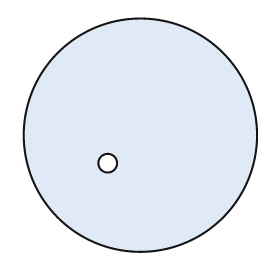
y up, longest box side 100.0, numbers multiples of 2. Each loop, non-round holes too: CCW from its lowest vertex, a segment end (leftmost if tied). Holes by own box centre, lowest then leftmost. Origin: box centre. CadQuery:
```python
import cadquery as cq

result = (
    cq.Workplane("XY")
    .moveTo(0.0, 0.0)
    .circle(50.0)
    .moveTo(-14.0, -12.0)
    .circle(4.0)
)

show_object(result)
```